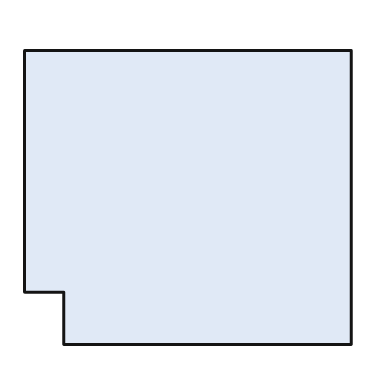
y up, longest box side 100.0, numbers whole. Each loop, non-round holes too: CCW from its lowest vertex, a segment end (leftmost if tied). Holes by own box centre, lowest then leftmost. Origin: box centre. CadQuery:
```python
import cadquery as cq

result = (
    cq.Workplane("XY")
    .moveTo(-38.0, -45.0)
    .lineTo(50.0, -45.0)
    .lineTo(50.0, 45.0)
    .lineTo(-50.0, 45.0)
    .lineTo(-50.0, -29.0)
    .lineTo(-38.0, -29.0)
    .close()
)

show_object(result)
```